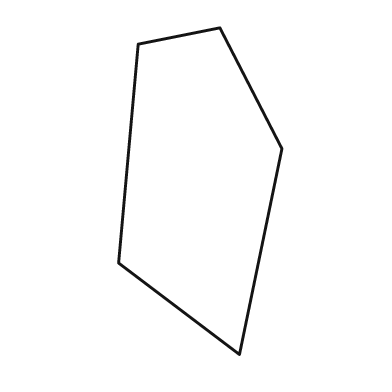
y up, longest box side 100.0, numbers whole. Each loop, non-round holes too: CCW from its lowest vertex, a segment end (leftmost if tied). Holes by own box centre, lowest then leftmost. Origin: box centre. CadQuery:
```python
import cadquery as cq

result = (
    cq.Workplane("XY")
    .moveTo(12.0, -50.0)
    .lineTo(25.0, 13.0)
    .lineTo(6.0, 50.0)
    .lineTo(-19.0, 45.0)
    .lineTo(-25.0, -22.0)
    .close()
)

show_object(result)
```